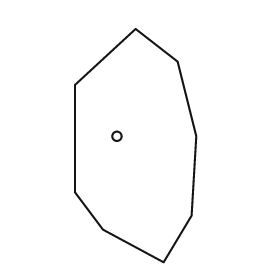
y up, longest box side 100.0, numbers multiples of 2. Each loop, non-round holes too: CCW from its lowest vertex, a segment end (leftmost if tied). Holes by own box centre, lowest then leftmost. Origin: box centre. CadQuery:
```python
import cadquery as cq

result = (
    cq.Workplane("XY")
    .moveTo(12.0, -50.0)
    .lineTo(24.0, -30.0)
    .lineTo(26.0, 4.0)
    .lineTo(18.0, 36.0)
    .lineTo(0.0, 50.0)
    .lineTo(-26.0, 26.0)
    .lineTo(-26.0, -20.0)
    .lineTo(-14.0, -36.0)
    .close()
    .moveTo(-8.0, 4.0)
    .circle(2.0)
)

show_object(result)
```